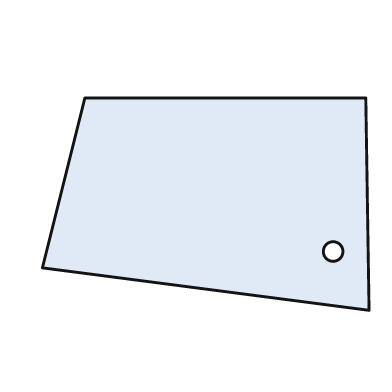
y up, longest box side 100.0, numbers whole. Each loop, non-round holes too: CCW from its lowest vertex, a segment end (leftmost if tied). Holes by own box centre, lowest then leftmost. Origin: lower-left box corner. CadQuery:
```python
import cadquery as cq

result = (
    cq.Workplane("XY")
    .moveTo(100.0, 0.0)
    .lineTo(99.0, 65.0)
    .lineTo(13.0, 65.0)
    .lineTo(0.0, 13.0)
    .close()
    .moveTo(89.0, 18.0)
    .circle(3.0)
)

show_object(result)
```